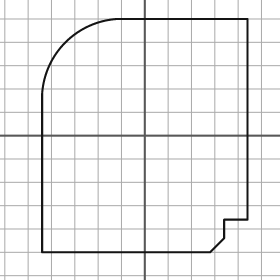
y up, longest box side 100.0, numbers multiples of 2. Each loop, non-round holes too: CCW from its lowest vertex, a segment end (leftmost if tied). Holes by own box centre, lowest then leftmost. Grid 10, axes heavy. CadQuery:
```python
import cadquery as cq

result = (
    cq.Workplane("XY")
    .moveTo(-44.0, -50.0)
    .lineTo(28.0, -50.0)
    .lineTo(34.0, -44.0)
    .lineTo(34.0, -36.0)
    .lineTo(44.0, -36.0)
    .lineTo(44.0, 50.0)
    .lineTo(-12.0, 50.0)
    .threePointArc((-34.0, 40.0), (-44.0, 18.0))
    .close()
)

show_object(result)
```